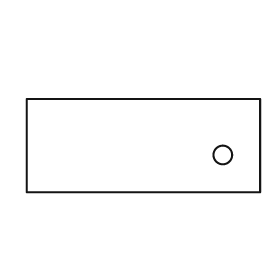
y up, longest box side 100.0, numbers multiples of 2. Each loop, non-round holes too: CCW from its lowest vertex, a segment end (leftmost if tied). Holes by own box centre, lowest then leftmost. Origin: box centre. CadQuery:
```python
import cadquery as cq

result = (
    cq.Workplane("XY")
    .moveTo(-50.0, -20.0)
    .lineTo(50.0, -20.0)
    .lineTo(50.0, 20.0)
    .lineTo(-50.0, 20.0)
    .close()
    .moveTo(34.0, -4.0)
    .circle(4.0)
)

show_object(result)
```